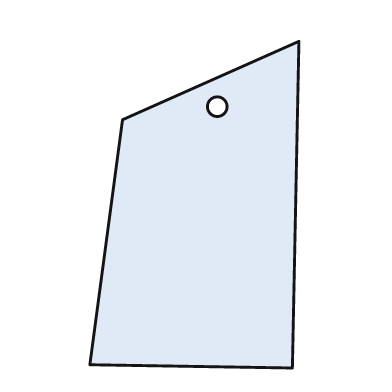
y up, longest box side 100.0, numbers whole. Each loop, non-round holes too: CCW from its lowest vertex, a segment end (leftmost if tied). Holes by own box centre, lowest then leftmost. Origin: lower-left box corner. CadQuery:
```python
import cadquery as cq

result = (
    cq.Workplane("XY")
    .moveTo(62.0, 0.0)
    .lineTo(64.0, 100.0)
    .lineTo(10.0, 76.0)
    .lineTo(0.0, 1.0)
    .close()
    .moveTo(39.0, 80.0)
    .circle(3.0)
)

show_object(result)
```